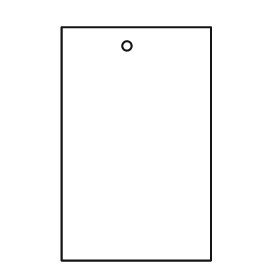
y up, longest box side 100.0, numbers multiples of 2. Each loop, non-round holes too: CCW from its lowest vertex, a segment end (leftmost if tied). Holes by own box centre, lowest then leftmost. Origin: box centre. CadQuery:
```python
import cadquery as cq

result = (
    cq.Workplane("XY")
    .moveTo(-32.0, -50.0)
    .lineTo(32.0, -50.0)
    .lineTo(32.0, 50.0)
    .lineTo(-32.0, 50.0)
    .close()
    .moveTo(-4.0, 42.0)
    .circle(2.0)
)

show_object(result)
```